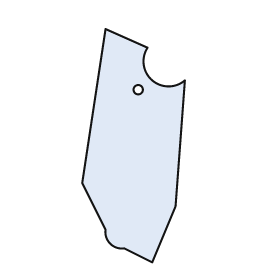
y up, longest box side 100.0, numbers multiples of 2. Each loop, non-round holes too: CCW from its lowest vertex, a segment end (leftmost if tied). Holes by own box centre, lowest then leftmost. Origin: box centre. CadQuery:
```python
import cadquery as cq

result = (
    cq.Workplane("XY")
    .moveTo(8.0, -50.0)
    .lineTo(18.0, -26.0)
    .lineTo(22.0, 28.0)
    .threePointArc((8.0, 28.0), (6.0, 42.0))
    .lineTo(-12.0, 50.0)
    .lineTo(-22.0, -16.0)
    .lineTo(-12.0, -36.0)
    .threePointArc((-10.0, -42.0), (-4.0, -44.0))
    .close()
    .moveTo(2.0, 24.0)
    .circle(2.0)
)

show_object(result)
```